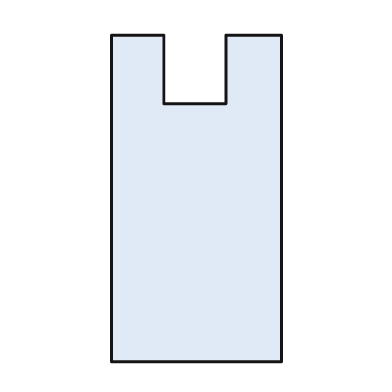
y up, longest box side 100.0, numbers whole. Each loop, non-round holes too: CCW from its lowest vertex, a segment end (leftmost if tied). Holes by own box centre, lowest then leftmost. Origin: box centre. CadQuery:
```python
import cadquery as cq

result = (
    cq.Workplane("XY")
    .moveTo(-26.0, -50.0)
    .lineTo(26.0, -50.0)
    .lineTo(26.0, 50.0)
    .lineTo(9.0, 50.0)
    .lineTo(9.0, 29.0)
    .lineTo(-10.0, 29.0)
    .lineTo(-10.0, 50.0)
    .lineTo(-26.0, 50.0)
    .close()
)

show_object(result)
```